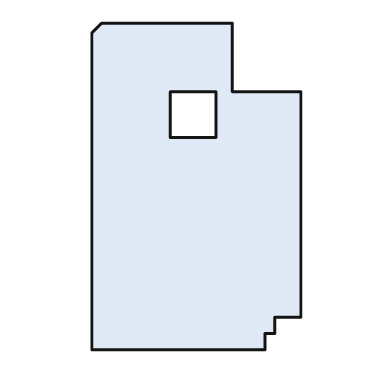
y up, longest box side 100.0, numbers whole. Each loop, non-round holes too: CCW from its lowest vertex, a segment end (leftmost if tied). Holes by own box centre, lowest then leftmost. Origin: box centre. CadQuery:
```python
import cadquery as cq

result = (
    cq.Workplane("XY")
    .moveTo(-32.0, -50.0)
    .lineTo(21.0, -50.0)
    .lineTo(21.0, -45.0)
    .lineTo(24.0, -45.0)
    .lineTo(24.0, -40.0)
    .lineTo(32.0, -40.0)
    .lineTo(32.0, 29.0)
    .lineTo(11.0, 29.0)
    .lineTo(11.0, 50.0)
    .lineTo(-29.0, 50.0)
    .lineTo(-32.0, 47.0)
    .close()
    .moveTo(-8.0, 15.0)
    .lineTo(6.0, 15.0)
    .lineTo(6.0, 29.0)
    .lineTo(-8.0, 29.0)
    .close()
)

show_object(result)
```